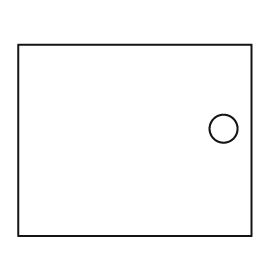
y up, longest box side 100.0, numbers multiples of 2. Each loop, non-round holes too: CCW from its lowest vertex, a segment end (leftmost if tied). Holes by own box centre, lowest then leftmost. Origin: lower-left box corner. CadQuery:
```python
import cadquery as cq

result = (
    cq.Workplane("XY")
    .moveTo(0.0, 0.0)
    .lineTo(100.0, 0.0)
    .lineTo(100.0, 82.0)
    .lineTo(0.0, 82.0)
    .close()
    .moveTo(88.0, 46.0)
    .circle(6.0)
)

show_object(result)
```